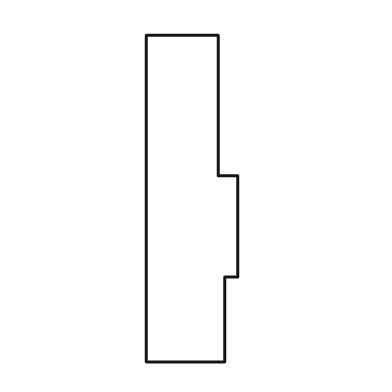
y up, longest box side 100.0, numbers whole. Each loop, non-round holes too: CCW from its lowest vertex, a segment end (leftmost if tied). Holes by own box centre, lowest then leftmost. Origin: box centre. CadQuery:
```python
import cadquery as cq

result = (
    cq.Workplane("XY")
    .moveTo(-14.0, -50.0)
    .lineTo(10.0, -50.0)
    .lineTo(10.0, -24.0)
    .lineTo(14.0, -24.0)
    .lineTo(14.0, 7.0)
    .lineTo(8.0, 7.0)
    .lineTo(8.0, 50.0)
    .lineTo(-14.0, 50.0)
    .close()
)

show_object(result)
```